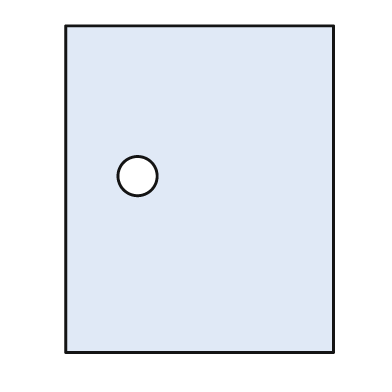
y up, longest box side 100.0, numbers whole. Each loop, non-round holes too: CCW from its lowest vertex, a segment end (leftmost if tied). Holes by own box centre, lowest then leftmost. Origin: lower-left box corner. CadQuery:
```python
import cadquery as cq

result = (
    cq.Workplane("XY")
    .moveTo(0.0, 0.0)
    .lineTo(82.0, 0.0)
    .lineTo(82.0, 100.0)
    .lineTo(0.0, 100.0)
    .close()
    .moveTo(22.0, 54.0)
    .circle(6.0)
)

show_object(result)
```